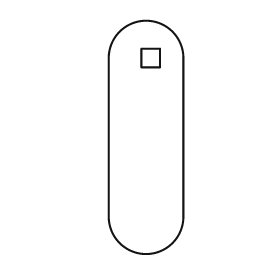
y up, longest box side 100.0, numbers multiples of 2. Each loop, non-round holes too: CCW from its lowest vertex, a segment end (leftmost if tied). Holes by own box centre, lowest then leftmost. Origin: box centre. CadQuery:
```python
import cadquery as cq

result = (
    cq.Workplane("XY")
    .moveTo(-16.0, -34.0)
    .threePointArc((0.0, -50.0), (16.0, -34.0))
    .lineTo(16.0, 34.0)
    .threePointArc((0.0, 50.0), (-16.0, 34.0))
    .close()
    .moveTo(-2.0, 30.0)
    .lineTo(6.0, 30.0)
    .lineTo(6.0, 38.0)
    .lineTo(-2.0, 38.0)
    .close()
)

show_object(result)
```